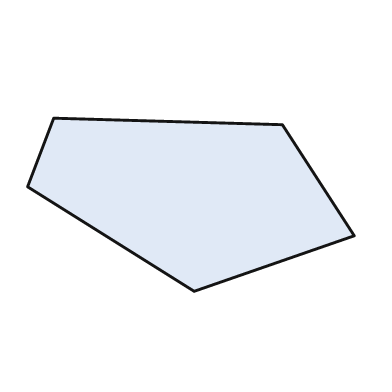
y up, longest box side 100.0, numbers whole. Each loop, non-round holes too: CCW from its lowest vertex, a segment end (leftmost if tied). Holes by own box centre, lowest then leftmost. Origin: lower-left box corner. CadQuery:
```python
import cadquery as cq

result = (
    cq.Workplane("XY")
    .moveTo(51.0, 0.0)
    .lineTo(100.0, 17.0)
    .lineTo(78.0, 51.0)
    .lineTo(8.0, 53.0)
    .lineTo(0.0, 32.0)
    .close()
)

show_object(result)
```